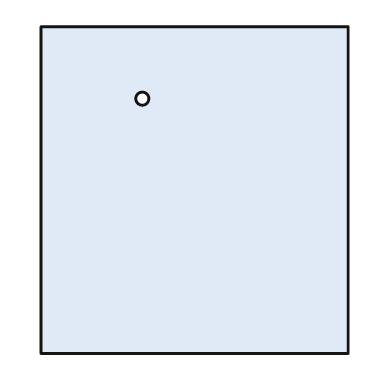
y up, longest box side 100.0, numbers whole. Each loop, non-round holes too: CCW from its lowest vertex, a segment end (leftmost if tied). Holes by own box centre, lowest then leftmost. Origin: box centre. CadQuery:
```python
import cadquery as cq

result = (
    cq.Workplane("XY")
    .moveTo(-47.0, -50.0)
    .lineTo(47.0, -50.0)
    .lineTo(47.0, 50.0)
    .lineTo(-47.0, 50.0)
    .close()
    .moveTo(-16.0, 28.0)
    .circle(2.0)
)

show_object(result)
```